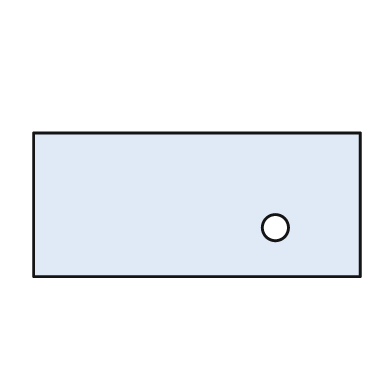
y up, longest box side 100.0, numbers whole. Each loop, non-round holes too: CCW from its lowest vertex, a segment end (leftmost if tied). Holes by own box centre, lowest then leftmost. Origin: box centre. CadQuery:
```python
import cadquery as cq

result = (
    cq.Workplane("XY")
    .moveTo(-50.0, -22.0)
    .lineTo(50.0, -22.0)
    .lineTo(50.0, 22.0)
    .lineTo(-50.0, 22.0)
    .close()
    .moveTo(24.0, -7.0)
    .circle(4.0)
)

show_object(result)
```